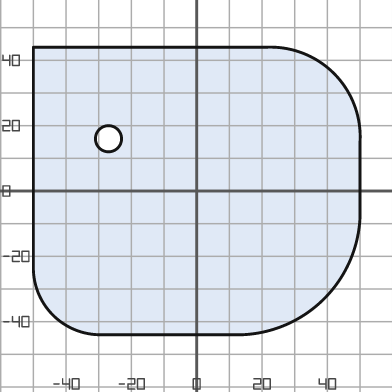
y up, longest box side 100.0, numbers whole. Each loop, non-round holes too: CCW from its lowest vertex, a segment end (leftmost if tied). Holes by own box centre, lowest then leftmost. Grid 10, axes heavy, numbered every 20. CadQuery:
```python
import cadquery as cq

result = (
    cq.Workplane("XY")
    .moveTo(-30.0, -44.0)
    .lineTo(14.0, -44.0)
    .threePointArc((39.0, -33.0), (50.0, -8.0))
    .lineTo(50.0, 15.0)
    .threePointArc((42.0, 36.0), (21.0, 44.0))
    .lineTo(-50.0, 44.0)
    .lineTo(-50.0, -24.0)
    .threePointArc((-44.0, -38.0), (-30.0, -44.0))
    .close()
    .moveTo(-27.0, 16.0)
    .circle(4.0)
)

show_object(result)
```